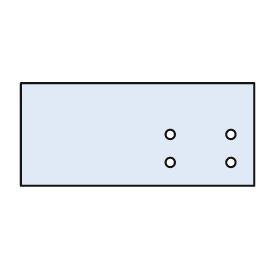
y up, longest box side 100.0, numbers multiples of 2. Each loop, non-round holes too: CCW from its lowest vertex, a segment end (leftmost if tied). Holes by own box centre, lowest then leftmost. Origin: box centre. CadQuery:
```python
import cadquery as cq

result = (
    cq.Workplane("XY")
    .moveTo(-50.0, -22.0)
    .lineTo(50.0, -22.0)
    .lineTo(50.0, 22.0)
    .lineTo(-50.0, 22.0)
    .close()
    .moveTo(14.0, -12.0)
    .circle(2.0)
    .moveTo(40.0, -12.0)
    .circle(2.0)
    .moveTo(14.0, 0.0)
    .circle(2.0)
    .moveTo(40.0, 0.0)
    .circle(2.0)
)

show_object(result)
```